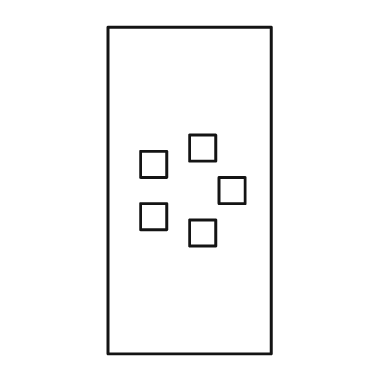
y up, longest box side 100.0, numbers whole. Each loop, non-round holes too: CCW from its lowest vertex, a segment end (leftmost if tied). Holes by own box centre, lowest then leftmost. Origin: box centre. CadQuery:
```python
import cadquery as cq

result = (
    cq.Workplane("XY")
    .moveTo(-25.0, -50.0)
    .lineTo(25.0, -50.0)
    .lineTo(25.0, 50.0)
    .lineTo(-25.0, 50.0)
    .close()
    .moveTo(0.0, -17.0)
    .lineTo(8.0, -17.0)
    .lineTo(8.0, -9.0)
    .lineTo(0.0, -9.0)
    .close()
    .moveTo(-15.0, -12.0)
    .lineTo(-7.0, -12.0)
    .lineTo(-7.0, -4.0)
    .lineTo(-15.0, -4.0)
    .close()
    .moveTo(9.0, -4.0)
    .lineTo(17.0, -4.0)
    .lineTo(17.0, 4.0)
    .lineTo(9.0, 4.0)
    .close()
    .moveTo(-15.0, 4.0)
    .lineTo(-7.0, 4.0)
    .lineTo(-7.0, 12.0)
    .lineTo(-15.0, 12.0)
    .close()
    .moveTo(0.0, 9.0)
    .lineTo(8.0, 9.0)
    .lineTo(8.0, 17.0)
    .lineTo(0.0, 17.0)
    .close()
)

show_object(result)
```